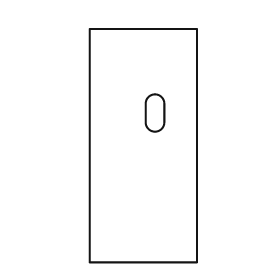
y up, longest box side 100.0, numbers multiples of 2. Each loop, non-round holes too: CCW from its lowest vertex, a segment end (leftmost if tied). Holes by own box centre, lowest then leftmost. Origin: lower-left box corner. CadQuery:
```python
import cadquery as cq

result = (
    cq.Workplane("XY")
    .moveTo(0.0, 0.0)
    .lineTo(46.0, 0.0)
    .lineTo(46.0, 100.0)
    .lineTo(0.0, 100.0)
    .close()
    .moveTo(24.0, 60.0)
    .threePointArc((28.0, 56.0), (32.0, 60.0))
    .lineTo(32.0, 68.0)
    .threePointArc((28.0, 72.0), (24.0, 68.0))
    .close()
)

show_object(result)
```